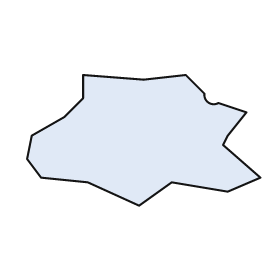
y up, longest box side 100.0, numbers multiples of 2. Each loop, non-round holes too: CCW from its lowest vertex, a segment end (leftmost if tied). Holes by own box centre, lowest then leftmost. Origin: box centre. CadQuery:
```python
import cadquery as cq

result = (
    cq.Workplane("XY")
    .moveTo(-2.0, -28.0)
    .lineTo(12.0, -18.0)
    .lineTo(36.0, -22.0)
    .lineTo(50.0, -16.0)
    .lineTo(34.0, -2.0)
    .lineTo(36.0, 2.0)
    .lineTo(44.0, 12.0)
    .lineTo(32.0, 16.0)
    .threePointArc((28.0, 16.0), (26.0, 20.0))
    .lineTo(18.0, 28.0)
    .lineTo(0.0, 26.0)
    .lineTo(-26.0, 28.0)
    .lineTo(-26.0, 18.0)
    .lineTo(-34.0, 10.0)
    .lineTo(-48.0, 2.0)
    .lineTo(-50.0, -8.0)
    .lineTo(-44.0, -16.0)
    .lineTo(-24.0, -18.0)
    .close()
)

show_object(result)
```